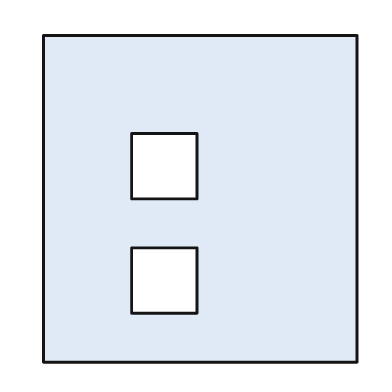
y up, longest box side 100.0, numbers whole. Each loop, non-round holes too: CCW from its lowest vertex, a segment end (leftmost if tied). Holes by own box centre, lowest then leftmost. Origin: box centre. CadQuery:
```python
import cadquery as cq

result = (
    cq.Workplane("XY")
    .moveTo(-48.0, -50.0)
    .lineTo(48.0, -50.0)
    .lineTo(48.0, 50.0)
    .lineTo(-48.0, 50.0)
    .close()
    .moveTo(-21.0, -35.0)
    .lineTo(-1.0, -35.0)
    .lineTo(-1.0, -15.0)
    .lineTo(-21.0, -15.0)
    .close()
    .moveTo(-21.0, 0.0)
    .lineTo(-1.0, 0.0)
    .lineTo(-1.0, 20.0)
    .lineTo(-21.0, 20.0)
    .close()
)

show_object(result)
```